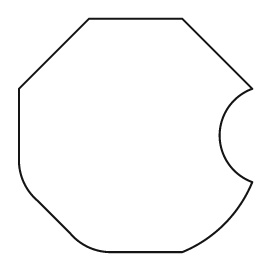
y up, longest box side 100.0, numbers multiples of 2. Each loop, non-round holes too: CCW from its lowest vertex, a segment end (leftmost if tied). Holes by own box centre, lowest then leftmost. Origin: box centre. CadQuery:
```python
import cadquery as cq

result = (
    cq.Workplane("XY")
    .moveTo(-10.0, -50.0)
    .lineTo(20.0, -50.0)
    .threePointArc((38.0, -38.0), (50.0, -20.0))
    .threePointArc((36.0, 0.0), (50.0, 20.0))
    .lineTo(20.0, 50.0)
    .lineTo(-20.0, 50.0)
    .lineTo(-50.0, 20.0)
    .lineTo(-50.0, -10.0)
    .threePointArc((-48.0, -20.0), (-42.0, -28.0))
    .lineTo(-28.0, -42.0)
    .threePointArc((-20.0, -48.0), (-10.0, -50.0))
    .close()
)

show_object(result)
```